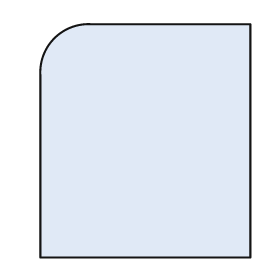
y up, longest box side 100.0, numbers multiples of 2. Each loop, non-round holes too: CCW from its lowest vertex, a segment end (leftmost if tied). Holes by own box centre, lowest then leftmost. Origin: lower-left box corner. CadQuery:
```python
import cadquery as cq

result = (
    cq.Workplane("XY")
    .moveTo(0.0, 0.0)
    .lineTo(90.0, 0.0)
    .lineTo(90.0, 100.0)
    .lineTo(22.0, 100.0)
    .threePointArc((6.0, 94.0), (0.0, 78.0))
    .close()
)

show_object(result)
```